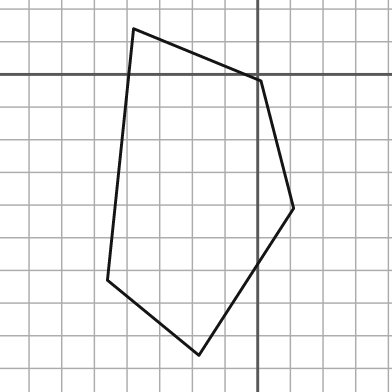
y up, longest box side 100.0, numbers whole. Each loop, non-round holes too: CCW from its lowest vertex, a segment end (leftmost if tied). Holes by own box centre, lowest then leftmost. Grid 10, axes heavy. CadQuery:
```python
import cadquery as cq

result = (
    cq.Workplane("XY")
    .moveTo(-18.0, -86.0)
    .lineTo(11.0, -41.0)
    .lineTo(1.0, -2.0)
    .lineTo(-38.0, 14.0)
    .lineTo(-46.0, -63.0)
    .close()
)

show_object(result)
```